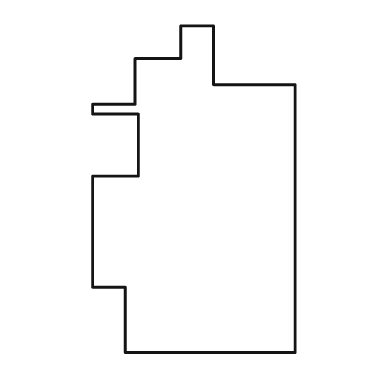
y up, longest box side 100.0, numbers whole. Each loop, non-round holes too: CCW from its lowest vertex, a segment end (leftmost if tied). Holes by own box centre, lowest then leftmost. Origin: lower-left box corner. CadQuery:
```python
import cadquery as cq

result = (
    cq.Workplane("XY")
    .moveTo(10.0, 0.0)
    .lineTo(62.0, 0.0)
    .lineTo(62.0, 82.0)
    .lineTo(37.0, 82.0)
    .lineTo(37.0, 100.0)
    .lineTo(27.0, 100.0)
    .lineTo(27.0, 90.0)
    .lineTo(13.0, 90.0)
    .lineTo(13.0, 76.0)
    .lineTo(0.0, 76.0)
    .lineTo(0.0, 73.0)
    .lineTo(14.0, 73.0)
    .lineTo(14.0, 54.0)
    .lineTo(0.0, 54.0)
    .lineTo(0.0, 20.0)
    .lineTo(10.0, 20.0)
    .close()
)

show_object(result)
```